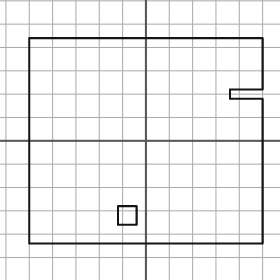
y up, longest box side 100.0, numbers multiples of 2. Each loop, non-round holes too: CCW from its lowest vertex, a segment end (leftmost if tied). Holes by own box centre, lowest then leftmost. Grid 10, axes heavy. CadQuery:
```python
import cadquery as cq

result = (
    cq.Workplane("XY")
    .moveTo(-50.0, -44.0)
    .lineTo(50.0, -44.0)
    .lineTo(50.0, 18.0)
    .lineTo(36.0, 18.0)
    .lineTo(36.0, 22.0)
    .lineTo(50.0, 22.0)
    .lineTo(50.0, 44.0)
    .lineTo(-50.0, 44.0)
    .close()
    .moveTo(-12.0, -36.0)
    .lineTo(-4.0, -36.0)
    .lineTo(-4.0, -28.0)
    .lineTo(-12.0, -28.0)
    .close()
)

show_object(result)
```